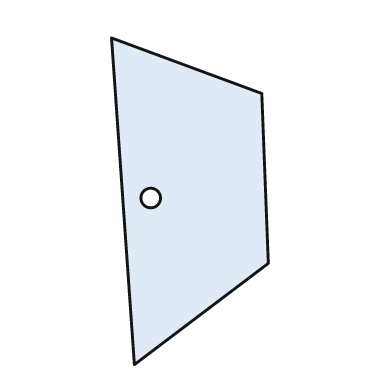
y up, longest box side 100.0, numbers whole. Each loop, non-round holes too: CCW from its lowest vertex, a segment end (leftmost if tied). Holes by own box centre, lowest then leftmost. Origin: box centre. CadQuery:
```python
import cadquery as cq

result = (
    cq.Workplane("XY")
    .moveTo(-17.0, -50.0)
    .lineTo(24.0, -19.0)
    .lineTo(22.0, 33.0)
    .lineTo(-24.0, 50.0)
    .close()
    .moveTo(-12.0, 1.0)
    .circle(3.0)
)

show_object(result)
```